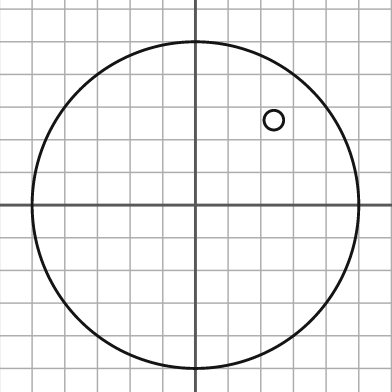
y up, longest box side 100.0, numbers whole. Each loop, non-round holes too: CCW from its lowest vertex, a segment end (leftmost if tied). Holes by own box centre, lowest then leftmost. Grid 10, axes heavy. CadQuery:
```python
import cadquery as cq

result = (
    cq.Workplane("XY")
    .moveTo(0.0, 0.0)
    .circle(50.0)
    .moveTo(24.0, 26.0)
    .circle(3.0)
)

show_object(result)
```